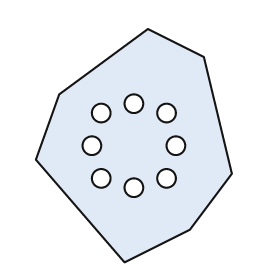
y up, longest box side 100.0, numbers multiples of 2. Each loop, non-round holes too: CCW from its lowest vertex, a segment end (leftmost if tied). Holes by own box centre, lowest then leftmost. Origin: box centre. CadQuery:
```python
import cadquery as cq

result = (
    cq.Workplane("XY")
    .moveTo(-4.0, -50.0)
    .lineTo(24.0, -36.0)
    .lineTo(42.0, -12.0)
    .lineTo(30.0, 38.0)
    .lineTo(6.0, 50.0)
    .lineTo(-32.0, 22.0)
    .lineTo(-42.0, -6.0)
    .close()
    .moveTo(0.0, -18.0)
    .circle(4.0)
    .moveTo(-14.0, -14.0)
    .circle(4.0)
    .moveTo(14.0, -14.0)
    .circle(4.0)
    .moveTo(-18.0, 0.0)
    .circle(4.0)
    .moveTo(18.0, 0.0)
    .circle(4.0)
    .moveTo(-14.0, 14.0)
    .circle(4.0)
    .moveTo(14.0, 14.0)
    .circle(4.0)
    .moveTo(0.0, 18.0)
    .circle(4.0)
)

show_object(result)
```